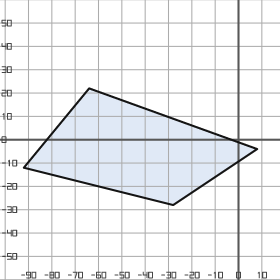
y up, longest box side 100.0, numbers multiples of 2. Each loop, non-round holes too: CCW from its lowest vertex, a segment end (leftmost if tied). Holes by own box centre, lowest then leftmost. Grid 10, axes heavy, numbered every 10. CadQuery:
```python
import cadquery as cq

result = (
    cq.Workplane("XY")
    .moveTo(-28.0, -28.0)
    .lineTo(8.0, -4.0)
    .lineTo(-64.0, 22.0)
    .lineTo(-92.0, -12.0)
    .close()
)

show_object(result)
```